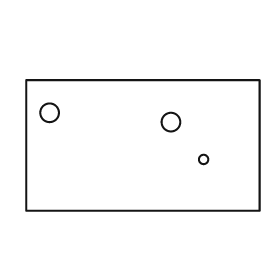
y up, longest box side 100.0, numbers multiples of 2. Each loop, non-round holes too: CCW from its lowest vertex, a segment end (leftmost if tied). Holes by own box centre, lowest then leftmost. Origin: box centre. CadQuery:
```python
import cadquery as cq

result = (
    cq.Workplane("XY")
    .moveTo(-50.0, -28.0)
    .lineTo(50.0, -28.0)
    .lineTo(50.0, 28.0)
    .lineTo(-50.0, 28.0)
    .close()
    .moveTo(26.0, -6.0)
    .circle(2.0)
    .moveTo(12.0, 10.0)
    .circle(4.0)
    .moveTo(-40.0, 14.0)
    .circle(4.0)
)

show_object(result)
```